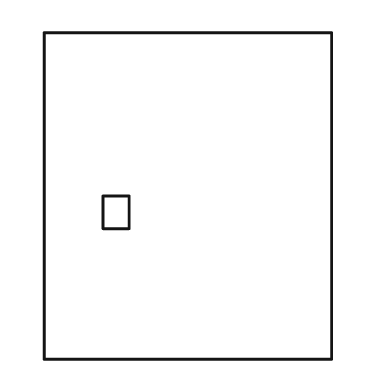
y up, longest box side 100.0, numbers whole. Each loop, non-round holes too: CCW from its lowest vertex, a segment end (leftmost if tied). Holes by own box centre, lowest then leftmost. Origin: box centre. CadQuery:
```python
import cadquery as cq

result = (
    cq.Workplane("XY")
    .moveTo(-44.0, -50.0)
    .lineTo(44.0, -50.0)
    .lineTo(44.0, 50.0)
    .lineTo(-44.0, 50.0)
    .close()
    .moveTo(-26.0, -10.0)
    .lineTo(-18.0, -10.0)
    .lineTo(-18.0, 0.0)
    .lineTo(-26.0, 0.0)
    .close()
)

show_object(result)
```